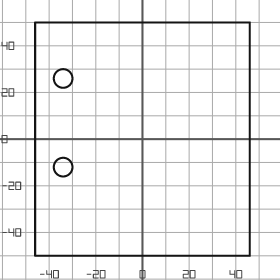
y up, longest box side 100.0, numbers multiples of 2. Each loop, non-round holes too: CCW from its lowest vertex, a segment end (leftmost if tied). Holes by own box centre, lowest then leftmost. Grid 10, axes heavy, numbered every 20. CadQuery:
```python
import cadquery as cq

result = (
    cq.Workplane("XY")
    .moveTo(-46.0, -50.0)
    .lineTo(46.0, -50.0)
    .lineTo(46.0, 50.0)
    .lineTo(-46.0, 50.0)
    .close()
    .moveTo(-34.0, -12.0)
    .circle(4.0)
    .moveTo(-34.0, 26.0)
    .circle(4.0)
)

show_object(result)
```